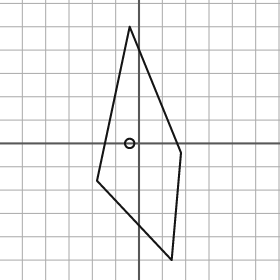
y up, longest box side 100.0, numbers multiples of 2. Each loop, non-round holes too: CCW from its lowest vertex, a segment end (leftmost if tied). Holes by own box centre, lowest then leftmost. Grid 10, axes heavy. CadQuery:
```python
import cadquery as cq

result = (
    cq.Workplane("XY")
    .moveTo(14.0, -50.0)
    .lineTo(18.0, -4.0)
    .lineTo(-4.0, 50.0)
    .lineTo(-18.0, -16.0)
    .close()
    .moveTo(-4.0, 0.0)
    .circle(2.0)
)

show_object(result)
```